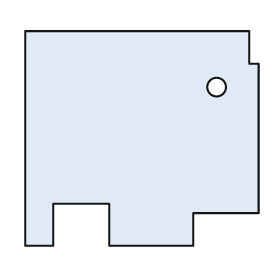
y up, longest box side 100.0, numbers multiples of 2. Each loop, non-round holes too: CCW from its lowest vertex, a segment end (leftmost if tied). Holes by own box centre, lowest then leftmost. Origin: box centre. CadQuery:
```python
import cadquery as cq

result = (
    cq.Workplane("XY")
    .moveTo(-50.0, -46.0)
    .lineTo(-38.0, -46.0)
    .lineTo(-38.0, -28.0)
    .lineTo(-14.0, -28.0)
    .lineTo(-14.0, -46.0)
    .lineTo(22.0, -46.0)
    .lineTo(22.0, -32.0)
    .lineTo(50.0, -32.0)
    .lineTo(50.0, 32.0)
    .lineTo(46.0, 32.0)
    .lineTo(46.0, 46.0)
    .lineTo(-50.0, 46.0)
    .close()
    .moveTo(32.0, 22.0)
    .circle(4.0)
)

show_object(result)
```